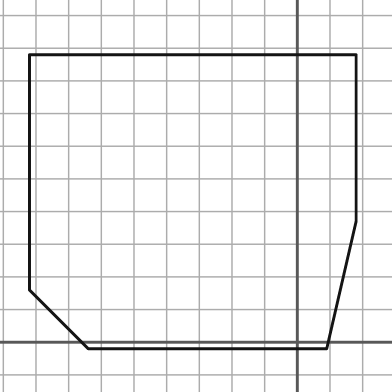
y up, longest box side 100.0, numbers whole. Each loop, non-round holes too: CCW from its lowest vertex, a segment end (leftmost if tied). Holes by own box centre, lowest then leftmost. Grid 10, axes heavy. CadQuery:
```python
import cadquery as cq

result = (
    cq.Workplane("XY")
    .moveTo(-64.0, -2.0)
    .lineTo(9.0, -2.0)
    .lineTo(18.0, 37.0)
    .lineTo(18.0, 88.0)
    .lineTo(-82.0, 88.0)
    .lineTo(-82.0, 16.0)
    .close()
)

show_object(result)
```